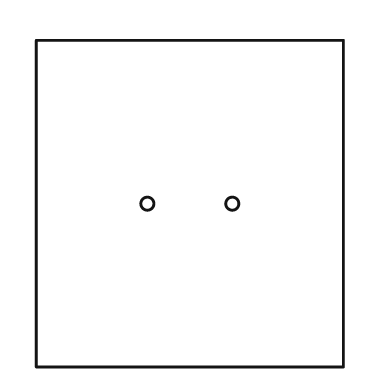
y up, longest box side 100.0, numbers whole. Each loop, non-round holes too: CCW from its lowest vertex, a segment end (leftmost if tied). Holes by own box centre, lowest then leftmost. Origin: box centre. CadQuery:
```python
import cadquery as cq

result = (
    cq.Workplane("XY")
    .moveTo(-47.0, -50.0)
    .lineTo(47.0, -50.0)
    .lineTo(47.0, 50.0)
    .lineTo(-47.0, 50.0)
    .close()
    .moveTo(-13.0, 0.0)
    .circle(2.0)
    .moveTo(13.0, 0.0)
    .circle(2.0)
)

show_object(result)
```